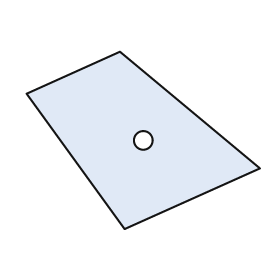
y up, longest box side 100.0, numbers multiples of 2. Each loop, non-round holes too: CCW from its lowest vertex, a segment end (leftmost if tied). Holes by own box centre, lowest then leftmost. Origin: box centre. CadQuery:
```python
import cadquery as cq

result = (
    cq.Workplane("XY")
    .moveTo(-8.0, -38.0)
    .lineTo(50.0, -12.0)
    .lineTo(-10.0, 38.0)
    .lineTo(-50.0, 20.0)
    .close()
    .moveTo(0.0, 0.0)
    .circle(4.0)
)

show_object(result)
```